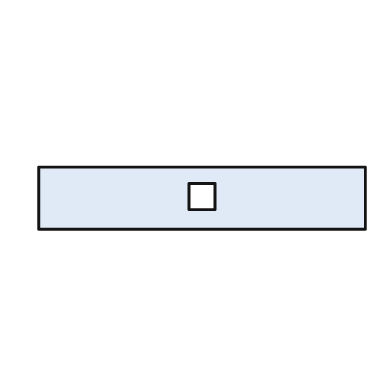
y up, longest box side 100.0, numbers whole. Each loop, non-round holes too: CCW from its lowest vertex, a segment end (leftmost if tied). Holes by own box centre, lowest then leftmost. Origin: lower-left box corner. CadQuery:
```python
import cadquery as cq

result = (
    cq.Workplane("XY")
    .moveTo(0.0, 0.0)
    .lineTo(100.0, 0.0)
    .lineTo(100.0, 19.0)
    .lineTo(0.0, 19.0)
    .close()
    .moveTo(46.0, 6.0)
    .lineTo(54.0, 6.0)
    .lineTo(54.0, 14.0)
    .lineTo(46.0, 14.0)
    .close()
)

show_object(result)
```